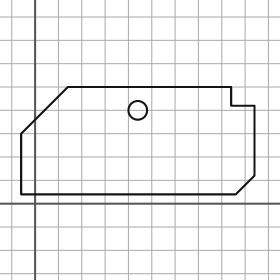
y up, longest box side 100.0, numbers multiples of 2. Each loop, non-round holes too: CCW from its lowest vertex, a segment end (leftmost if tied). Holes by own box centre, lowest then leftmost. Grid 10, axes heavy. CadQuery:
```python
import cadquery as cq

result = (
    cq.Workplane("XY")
    .moveTo(-6.0, 4.0)
    .lineTo(86.0, 4.0)
    .lineTo(94.0, 12.0)
    .lineTo(94.0, 42.0)
    .lineTo(84.0, 42.0)
    .lineTo(84.0, 50.0)
    .lineTo(14.0, 50.0)
    .lineTo(-6.0, 30.0)
    .close()
    .moveTo(44.0, 40.0)
    .circle(4.0)
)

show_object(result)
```